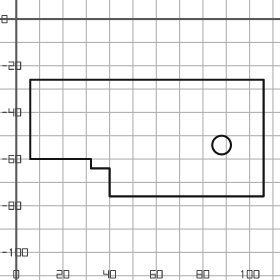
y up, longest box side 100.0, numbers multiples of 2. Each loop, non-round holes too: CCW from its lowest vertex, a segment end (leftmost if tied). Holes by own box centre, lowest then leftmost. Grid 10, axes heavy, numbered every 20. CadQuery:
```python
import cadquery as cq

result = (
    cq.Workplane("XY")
    .moveTo(40.0, -76.0)
    .lineTo(106.0, -76.0)
    .lineTo(106.0, -26.0)
    .lineTo(6.0, -26.0)
    .lineTo(6.0, -60.0)
    .lineTo(32.0, -60.0)
    .lineTo(32.0, -64.0)
    .lineTo(40.0, -64.0)
    .close()
    .moveTo(88.0, -54.0)
    .circle(4.0)
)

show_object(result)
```